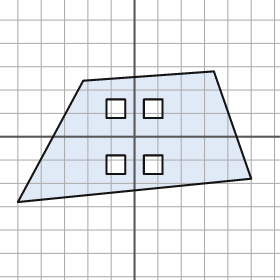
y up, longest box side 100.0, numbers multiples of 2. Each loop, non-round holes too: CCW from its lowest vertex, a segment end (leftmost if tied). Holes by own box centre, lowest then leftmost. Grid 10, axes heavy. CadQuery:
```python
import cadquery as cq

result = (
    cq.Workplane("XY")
    .moveTo(-50.0, -28.0)
    .lineTo(50.0, -18.0)
    .lineTo(34.0, 28.0)
    .lineTo(-22.0, 24.0)
    .close()
    .moveTo(-12.0, -16.0)
    .lineTo(-4.0, -16.0)
    .lineTo(-4.0, -8.0)
    .lineTo(-12.0, -8.0)
    .close()
    .moveTo(4.0, -16.0)
    .lineTo(12.0, -16.0)
    .lineTo(12.0, -8.0)
    .lineTo(4.0, -8.0)
    .close()
    .moveTo(-12.0, 8.0)
    .lineTo(-4.0, 8.0)
    .lineTo(-4.0, 16.0)
    .lineTo(-12.0, 16.0)
    .close()
    .moveTo(4.0, 8.0)
    .lineTo(12.0, 8.0)
    .lineTo(12.0, 16.0)
    .lineTo(4.0, 16.0)
    .close()
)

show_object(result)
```